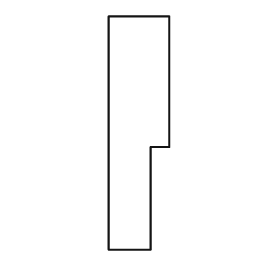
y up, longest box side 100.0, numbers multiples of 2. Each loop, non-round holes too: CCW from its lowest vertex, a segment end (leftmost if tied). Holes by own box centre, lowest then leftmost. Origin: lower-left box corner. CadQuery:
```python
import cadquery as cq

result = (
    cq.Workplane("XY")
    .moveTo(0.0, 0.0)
    .lineTo(18.0, 0.0)
    .lineTo(18.0, 44.0)
    .lineTo(26.0, 44.0)
    .lineTo(26.0, 100.0)
    .lineTo(0.0, 100.0)
    .close()
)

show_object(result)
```